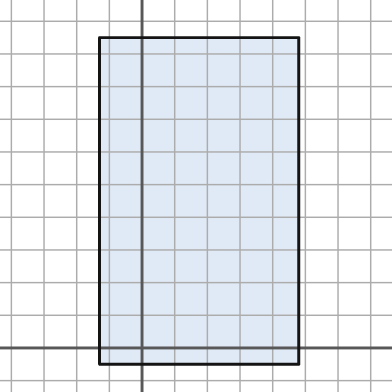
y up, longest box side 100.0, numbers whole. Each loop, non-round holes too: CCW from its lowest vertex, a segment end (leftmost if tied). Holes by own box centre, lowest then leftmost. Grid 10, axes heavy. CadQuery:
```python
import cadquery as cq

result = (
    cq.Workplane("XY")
    .moveTo(-13.0, -5.0)
    .lineTo(48.0, -5.0)
    .lineTo(48.0, 95.0)
    .lineTo(-13.0, 95.0)
    .close()
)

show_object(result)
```